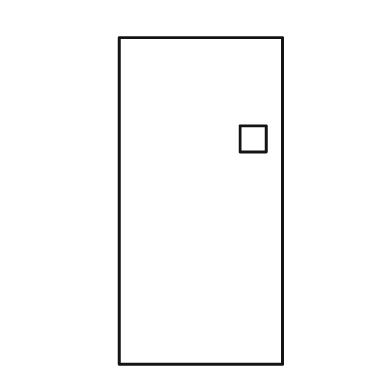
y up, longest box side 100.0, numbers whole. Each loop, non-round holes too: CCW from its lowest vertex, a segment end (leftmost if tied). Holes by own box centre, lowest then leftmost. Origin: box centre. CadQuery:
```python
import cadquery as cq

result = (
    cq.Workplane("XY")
    .moveTo(-25.0, -50.0)
    .lineTo(25.0, -50.0)
    .lineTo(25.0, 50.0)
    .lineTo(-25.0, 50.0)
    .close()
    .moveTo(12.0, 15.0)
    .lineTo(20.0, 15.0)
    .lineTo(20.0, 23.0)
    .lineTo(12.0, 23.0)
    .close()
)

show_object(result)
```